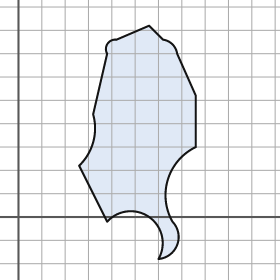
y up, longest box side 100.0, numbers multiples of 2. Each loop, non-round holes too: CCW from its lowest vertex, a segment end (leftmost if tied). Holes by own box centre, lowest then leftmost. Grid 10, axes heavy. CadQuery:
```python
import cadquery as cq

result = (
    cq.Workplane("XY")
    .moveTo(60.0, -18.0)
    .threePointArc((68.0, -12.0), (66.0, -2.0))
    .threePointArc((64.0, 16.0), (76.0, 30.0))
    .lineTo(76.0, 52.0)
    .lineTo(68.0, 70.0)
    .threePointArc((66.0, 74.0), (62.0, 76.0))
    .lineTo(56.0, 82.0)
    .lineTo(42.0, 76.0)
    .threePointArc((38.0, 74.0), (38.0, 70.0))
    .lineTo(32.0, 44.0)
    .threePointArc((32.0, 32.0), (26.0, 22.0))
    .lineTo(38.0, -2.0)
    .threePointArc((56.0, 0.0), (60.0, -18.0))
    .close()
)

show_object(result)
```